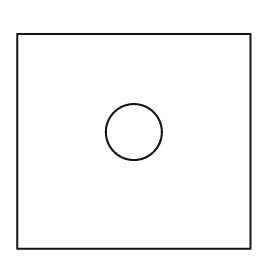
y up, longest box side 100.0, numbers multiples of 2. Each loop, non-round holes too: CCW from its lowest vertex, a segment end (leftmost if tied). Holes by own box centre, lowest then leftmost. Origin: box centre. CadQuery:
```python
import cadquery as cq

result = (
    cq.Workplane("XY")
    .moveTo(-50.0, -46.0)
    .lineTo(50.0, -46.0)
    .lineTo(50.0, 46.0)
    .lineTo(-50.0, 46.0)
    .close()
    .moveTo(0.0, 4.0)
    .circle(12.0)
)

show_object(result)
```